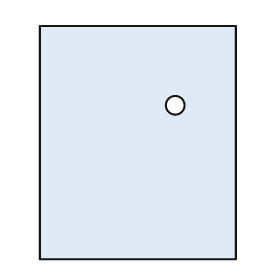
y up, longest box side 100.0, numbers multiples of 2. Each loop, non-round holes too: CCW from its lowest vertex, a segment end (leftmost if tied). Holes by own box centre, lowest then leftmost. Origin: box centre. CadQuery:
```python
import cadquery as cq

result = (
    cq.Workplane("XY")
    .moveTo(-42.0, -50.0)
    .lineTo(42.0, -50.0)
    .lineTo(42.0, 50.0)
    .lineTo(-42.0, 50.0)
    .close()
    .moveTo(16.0, 16.0)
    .circle(4.0)
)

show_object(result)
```